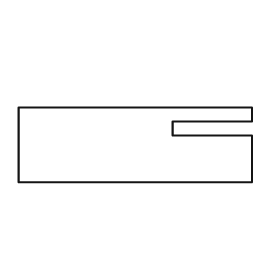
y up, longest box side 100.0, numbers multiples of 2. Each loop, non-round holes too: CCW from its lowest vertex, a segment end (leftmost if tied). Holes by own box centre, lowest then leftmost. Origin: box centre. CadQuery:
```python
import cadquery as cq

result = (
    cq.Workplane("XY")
    .moveTo(-50.0, -16.0)
    .lineTo(50.0, -16.0)
    .lineTo(50.0, 4.0)
    .lineTo(16.0, 4.0)
    .lineTo(16.0, 10.0)
    .lineTo(50.0, 10.0)
    .lineTo(50.0, 16.0)
    .lineTo(-50.0, 16.0)
    .close()
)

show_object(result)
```